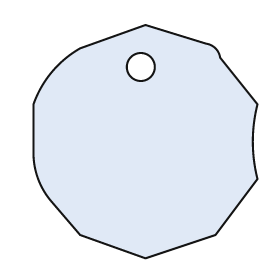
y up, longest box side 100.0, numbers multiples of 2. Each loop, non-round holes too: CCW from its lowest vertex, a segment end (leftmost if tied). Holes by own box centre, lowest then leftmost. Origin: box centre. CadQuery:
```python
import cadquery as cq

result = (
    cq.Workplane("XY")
    .moveTo(0.0, -50.0)
    .lineTo(30.0, -40.0)
    .lineTo(48.0, -16.0)
    .threePointArc((46.0, 0.0), (48.0, 16.0))
    .lineTo(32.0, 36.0)
    .threePointArc((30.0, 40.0), (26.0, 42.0))
    .lineTo(0.0, 50.0)
    .lineTo(-28.0, 40.0)
    .threePointArc((-40.0, 30.0), (-48.0, 16.0))
    .lineTo(-48.0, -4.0)
    .threePointArc((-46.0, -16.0), (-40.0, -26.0))
    .lineTo(-28.0, -40.0)
    .close()
    .moveTo(-2.0, 32.0)
    .circle(6.0)
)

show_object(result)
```